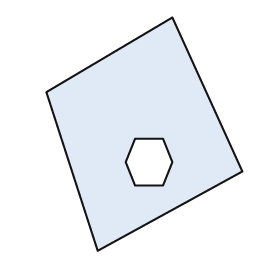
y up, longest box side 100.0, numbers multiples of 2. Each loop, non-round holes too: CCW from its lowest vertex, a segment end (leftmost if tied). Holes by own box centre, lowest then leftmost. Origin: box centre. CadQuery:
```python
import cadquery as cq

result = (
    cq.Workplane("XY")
    .moveTo(-20.0, -50.0)
    .lineTo(42.0, -16.0)
    .lineTo(12.0, 50.0)
    .lineTo(-42.0, 18.0)
    .close()
    .moveTo(-4.0, -22.0)
    .lineTo(8.0, -22.0)
    .lineTo(12.0, -12.0)
    .lineTo(8.0, -2.0)
    .lineTo(-4.0, -2.0)
    .lineTo(-8.0, -12.0)
    .close()
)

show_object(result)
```